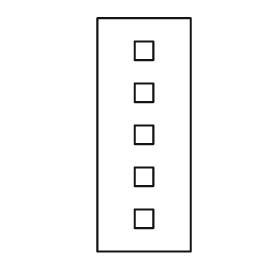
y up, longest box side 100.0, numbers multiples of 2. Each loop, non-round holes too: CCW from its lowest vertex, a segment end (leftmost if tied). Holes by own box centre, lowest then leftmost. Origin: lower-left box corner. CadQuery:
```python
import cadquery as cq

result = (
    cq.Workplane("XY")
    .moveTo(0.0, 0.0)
    .lineTo(40.0, 0.0)
    .lineTo(40.0, 100.0)
    .lineTo(0.0, 100.0)
    .close()
    .moveTo(16.0, 10.0)
    .lineTo(24.0, 10.0)
    .lineTo(24.0, 18.0)
    .lineTo(16.0, 18.0)
    .close()
    .moveTo(16.0, 28.0)
    .lineTo(24.0, 28.0)
    .lineTo(24.0, 36.0)
    .lineTo(16.0, 36.0)
    .close()
    .moveTo(16.0, 46.0)
    .lineTo(24.0, 46.0)
    .lineTo(24.0, 54.0)
    .lineTo(16.0, 54.0)
    .close()
    .moveTo(16.0, 64.0)
    .lineTo(24.0, 64.0)
    .lineTo(24.0, 72.0)
    .lineTo(16.0, 72.0)
    .close()
    .moveTo(16.0, 82.0)
    .lineTo(24.0, 82.0)
    .lineTo(24.0, 90.0)
    .lineTo(16.0, 90.0)
    .close()
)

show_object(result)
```